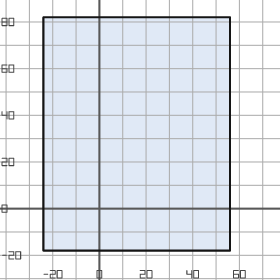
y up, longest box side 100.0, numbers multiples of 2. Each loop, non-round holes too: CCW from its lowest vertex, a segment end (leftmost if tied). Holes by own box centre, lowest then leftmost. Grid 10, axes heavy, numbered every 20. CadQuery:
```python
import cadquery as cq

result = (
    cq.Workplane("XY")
    .moveTo(-24.0, -18.0)
    .lineTo(56.0, -18.0)
    .lineTo(56.0, 82.0)
    .lineTo(-24.0, 82.0)
    .close()
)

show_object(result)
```